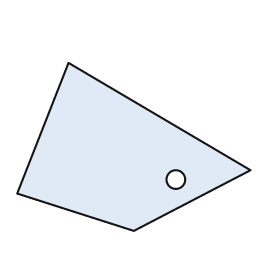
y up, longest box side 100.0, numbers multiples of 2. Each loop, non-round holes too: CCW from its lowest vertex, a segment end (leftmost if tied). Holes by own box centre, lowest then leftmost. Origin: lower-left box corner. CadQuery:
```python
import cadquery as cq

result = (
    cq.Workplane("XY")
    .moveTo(50.0, 0.0)
    .lineTo(100.0, 26.0)
    .lineTo(22.0, 72.0)
    .lineTo(0.0, 16.0)
    .close()
    .moveTo(68.0, 22.0)
    .circle(4.0)
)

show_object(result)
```